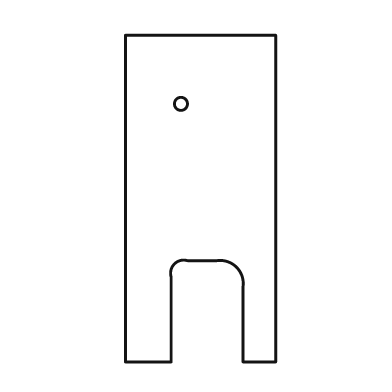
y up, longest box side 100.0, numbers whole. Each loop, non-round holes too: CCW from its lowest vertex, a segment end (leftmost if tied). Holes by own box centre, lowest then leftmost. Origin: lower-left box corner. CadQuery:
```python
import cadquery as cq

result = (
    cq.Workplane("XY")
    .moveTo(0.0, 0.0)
    .lineTo(14.0, 0.0)
    .lineTo(14.0, 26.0)
    .threePointArc((15.0, 30.0), (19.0, 31.0))
    .lineTo(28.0, 31.0)
    .threePointArc((34.0, 29.0), (36.0, 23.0))
    .lineTo(36.0, 0.0)
    .lineTo(46.0, 0.0)
    .lineTo(46.0, 100.0)
    .lineTo(0.0, 100.0)
    .close()
    .moveTo(17.0, 79.0)
    .circle(2.0)
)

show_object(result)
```